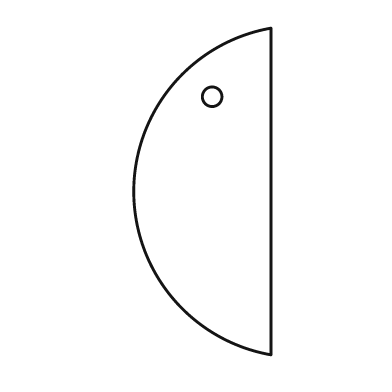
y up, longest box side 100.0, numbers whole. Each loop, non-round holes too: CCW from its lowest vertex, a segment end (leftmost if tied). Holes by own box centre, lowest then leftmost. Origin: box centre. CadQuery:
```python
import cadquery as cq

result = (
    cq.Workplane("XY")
    .moveTo(21.0, -50.0)
    .lineTo(21.0, 50.0)
    .threePointArc((-21.0, 0.0), (21.0, -50.0))
    .close()
    .moveTo(3.0, 29.0)
    .circle(3.0)
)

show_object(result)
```